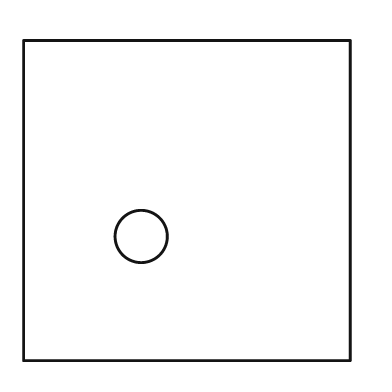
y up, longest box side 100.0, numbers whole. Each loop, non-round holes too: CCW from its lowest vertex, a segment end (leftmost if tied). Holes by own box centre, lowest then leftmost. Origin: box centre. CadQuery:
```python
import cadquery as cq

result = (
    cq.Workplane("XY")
    .moveTo(-50.0, -49.0)
    .lineTo(50.0, -49.0)
    .lineTo(50.0, 49.0)
    .lineTo(-50.0, 49.0)
    .close()
    .moveTo(-14.0, -11.0)
    .circle(8.0)
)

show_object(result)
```